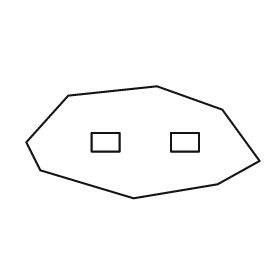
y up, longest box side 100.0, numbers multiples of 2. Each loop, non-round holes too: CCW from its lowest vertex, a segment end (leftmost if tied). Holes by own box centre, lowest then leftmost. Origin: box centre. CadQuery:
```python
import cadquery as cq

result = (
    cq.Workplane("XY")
    .moveTo(-4.0, -24.0)
    .lineTo(32.0, -18.0)
    .lineTo(50.0, -8.0)
    .lineTo(34.0, 14.0)
    .lineTo(6.0, 24.0)
    .lineTo(-32.0, 20.0)
    .lineTo(-50.0, 0.0)
    .lineTo(-44.0, -12.0)
    .close()
    .moveTo(-22.0, -4.0)
    .lineTo(-10.0, -4.0)
    .lineTo(-10.0, 4.0)
    .lineTo(-22.0, 4.0)
    .close()
    .moveTo(12.0, -4.0)
    .lineTo(24.0, -4.0)
    .lineTo(24.0, 4.0)
    .lineTo(12.0, 4.0)
    .close()
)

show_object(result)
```